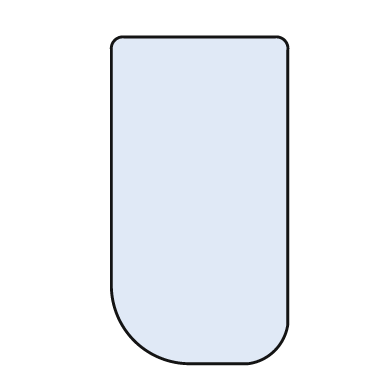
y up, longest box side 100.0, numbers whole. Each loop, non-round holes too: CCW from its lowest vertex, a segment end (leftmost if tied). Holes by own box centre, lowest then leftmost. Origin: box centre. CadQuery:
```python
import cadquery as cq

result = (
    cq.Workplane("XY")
    .moveTo(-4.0, -50.0)
    .lineTo(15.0, -50.0)
    .threePointArc((23.0, -46.0), (27.0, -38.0))
    .lineTo(27.0, 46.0)
    .threePointArc((26.0, 49.0), (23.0, 50.0))
    .lineTo(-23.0, 50.0)
    .threePointArc((-26.0, 49.0), (-27.0, 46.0))
    .lineTo(-27.0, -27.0)
    .threePointArc((-20.0, -43.0), (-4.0, -50.0))
    .close()
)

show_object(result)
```